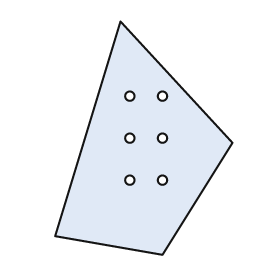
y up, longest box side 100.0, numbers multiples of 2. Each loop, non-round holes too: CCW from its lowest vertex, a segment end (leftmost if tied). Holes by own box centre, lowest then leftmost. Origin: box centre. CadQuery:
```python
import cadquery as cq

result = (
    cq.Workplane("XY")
    .moveTo(8.0, -50.0)
    .lineTo(38.0, -2.0)
    .lineTo(-10.0, 50.0)
    .lineTo(-38.0, -42.0)
    .close()
    .moveTo(-6.0, -18.0)
    .circle(2.0)
    .moveTo(8.0, -18.0)
    .circle(2.0)
    .moveTo(-6.0, 0.0)
    .circle(2.0)
    .moveTo(8.0, 0.0)
    .circle(2.0)
    .moveTo(-6.0, 18.0)
    .circle(2.0)
    .moveTo(8.0, 18.0)
    .circle(2.0)
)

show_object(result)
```